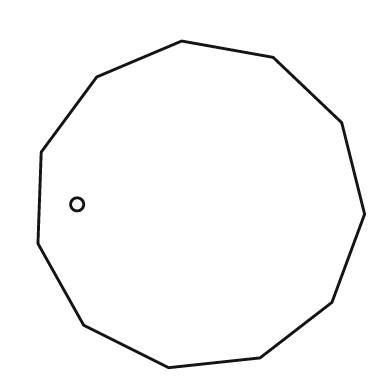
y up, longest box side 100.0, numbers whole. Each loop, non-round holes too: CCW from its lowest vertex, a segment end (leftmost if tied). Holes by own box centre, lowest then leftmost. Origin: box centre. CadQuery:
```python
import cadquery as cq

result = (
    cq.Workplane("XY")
    .moveTo(-10.0, -50.0)
    .lineTo(18.0, -47.0)
    .lineTo(40.0, -30.0)
    .lineTo(50.0, -3.0)
    .lineTo(43.0, 25.0)
    .lineTo(22.0, 45.0)
    .lineTo(-6.0, 50.0)
    .lineTo(-32.0, 39.0)
    .lineTo(-49.0, 16.0)
    .lineTo(-50.0, -12.0)
    .lineTo(-36.0, -37.0)
    .close()
    .moveTo(-38.0, 0.0)
    .circle(2.0)
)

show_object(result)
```